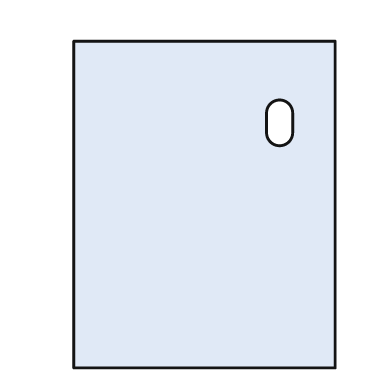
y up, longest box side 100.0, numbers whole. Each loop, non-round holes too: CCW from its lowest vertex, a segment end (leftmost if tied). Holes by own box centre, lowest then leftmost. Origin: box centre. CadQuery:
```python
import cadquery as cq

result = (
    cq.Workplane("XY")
    .moveTo(-40.0, -50.0)
    .lineTo(40.0, -50.0)
    .lineTo(40.0, 50.0)
    .lineTo(-40.0, 50.0)
    .close()
    .moveTo(19.0, 22.0)
    .threePointArc((23.0, 18.0), (27.0, 22.0))
    .lineTo(27.0, 28.0)
    .threePointArc((23.0, 32.0), (19.0, 28.0))
    .close()
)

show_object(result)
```